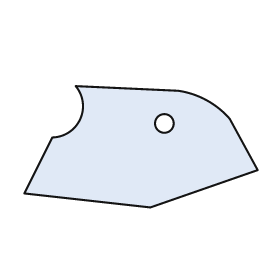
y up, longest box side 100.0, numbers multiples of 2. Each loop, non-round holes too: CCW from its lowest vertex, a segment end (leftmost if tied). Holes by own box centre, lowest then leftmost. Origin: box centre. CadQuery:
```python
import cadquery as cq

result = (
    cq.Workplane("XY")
    .moveTo(4.0, -26.0)
    .lineTo(50.0, -10.0)
    .lineTo(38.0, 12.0)
    .threePointArc((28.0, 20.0), (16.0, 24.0))
    .lineTo(-28.0, 26.0)
    .threePointArc((-26.0, 12.0), (-38.0, 4.0))
    .lineTo(-50.0, -20.0)
    .close()
    .moveTo(10.0, 10.0)
    .circle(4.0)
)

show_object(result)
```